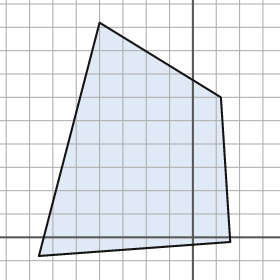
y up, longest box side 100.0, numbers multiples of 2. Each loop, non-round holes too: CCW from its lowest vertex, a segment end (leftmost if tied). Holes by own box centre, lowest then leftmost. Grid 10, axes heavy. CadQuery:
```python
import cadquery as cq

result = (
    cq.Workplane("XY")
    .moveTo(-66.0, -8.0)
    .lineTo(16.0, -2.0)
    .lineTo(12.0, 60.0)
    .lineTo(-40.0, 92.0)
    .close()
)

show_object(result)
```